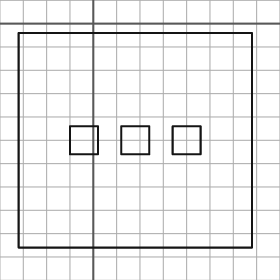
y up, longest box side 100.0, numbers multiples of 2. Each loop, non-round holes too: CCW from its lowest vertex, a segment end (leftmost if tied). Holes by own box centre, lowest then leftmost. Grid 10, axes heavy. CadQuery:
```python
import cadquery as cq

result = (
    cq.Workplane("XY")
    .moveTo(-32.0, -96.0)
    .lineTo(68.0, -96.0)
    .lineTo(68.0, -4.0)
    .lineTo(-32.0, -4.0)
    .close()
    .moveTo(-10.0, -56.0)
    .lineTo(2.0, -56.0)
    .lineTo(2.0, -44.0)
    .lineTo(-10.0, -44.0)
    .close()
    .moveTo(12.0, -56.0)
    .lineTo(24.0, -56.0)
    .lineTo(24.0, -44.0)
    .lineTo(12.0, -44.0)
    .close()
    .moveTo(34.0, -56.0)
    .lineTo(46.0, -56.0)
    .lineTo(46.0, -44.0)
    .lineTo(34.0, -44.0)
    .close()
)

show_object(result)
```